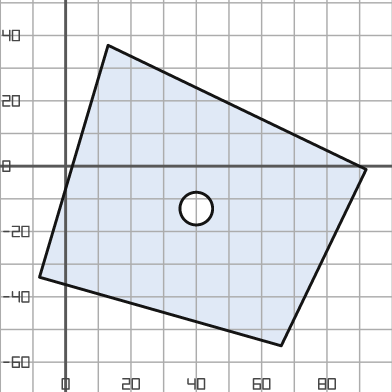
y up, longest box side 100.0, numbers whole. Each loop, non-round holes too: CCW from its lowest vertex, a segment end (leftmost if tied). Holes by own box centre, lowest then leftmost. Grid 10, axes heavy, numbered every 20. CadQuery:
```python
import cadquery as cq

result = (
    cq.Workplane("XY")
    .moveTo(66.0, -55.0)
    .lineTo(92.0, -1.0)
    .lineTo(13.0, 37.0)
    .lineTo(-8.0, -34.0)
    .close()
    .moveTo(40.0, -13.0)
    .circle(5.0)
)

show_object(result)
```